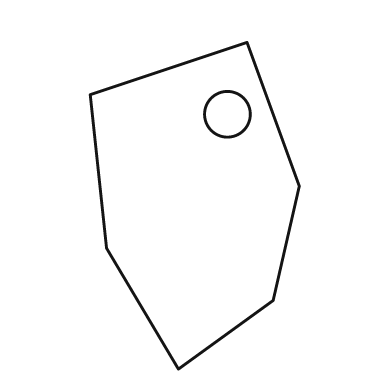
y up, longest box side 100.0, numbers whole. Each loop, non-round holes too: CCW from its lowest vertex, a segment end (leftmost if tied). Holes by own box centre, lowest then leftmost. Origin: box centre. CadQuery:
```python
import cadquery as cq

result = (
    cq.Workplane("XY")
    .moveTo(-5.0, -50.0)
    .lineTo(24.0, -29.0)
    .lineTo(32.0, 6.0)
    .lineTo(16.0, 50.0)
    .lineTo(-32.0, 34.0)
    .lineTo(-27.0, -13.0)
    .close()
    .moveTo(10.0, 28.0)
    .circle(7.0)
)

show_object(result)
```